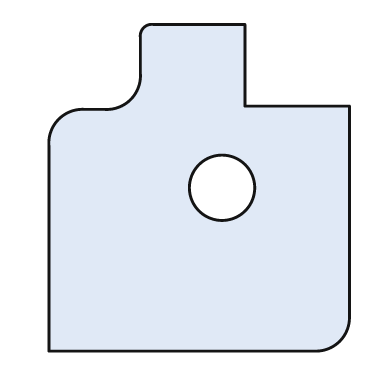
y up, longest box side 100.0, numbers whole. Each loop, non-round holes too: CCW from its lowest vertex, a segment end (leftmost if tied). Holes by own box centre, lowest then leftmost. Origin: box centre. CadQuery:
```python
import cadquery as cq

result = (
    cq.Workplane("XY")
    .moveTo(-46.0, -50.0)
    .lineTo(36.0, -50.0)
    .threePointArc((43.0, -47.0), (46.0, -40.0))
    .lineTo(46.0, 25.0)
    .lineTo(14.0, 25.0)
    .lineTo(14.0, 50.0)
    .lineTo(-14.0, 50.0)
    .threePointArc((-17.0, 49.0), (-18.0, 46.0))
    .lineTo(-18.0, 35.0)
    .threePointArc((-21.0, 27.0), (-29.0, 24.0))
    .lineTo(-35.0, 24.0)
    .threePointArc((-43.0, 21.0), (-46.0, 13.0))
    .close()
    .moveTo(7.0, 0.0)
    .circle(10.0)
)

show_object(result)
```